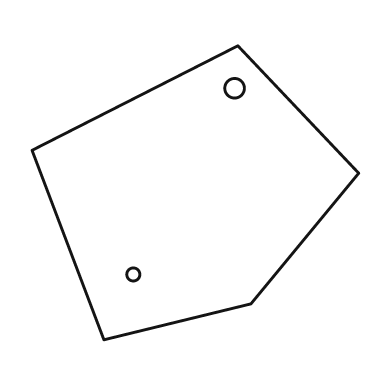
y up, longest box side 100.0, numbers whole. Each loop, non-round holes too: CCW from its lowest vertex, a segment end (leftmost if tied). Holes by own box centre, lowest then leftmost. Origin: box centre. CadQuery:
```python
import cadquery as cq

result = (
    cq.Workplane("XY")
    .moveTo(-28.0, -45.0)
    .lineTo(17.0, -34.0)
    .lineTo(50.0, 6.0)
    .lineTo(13.0, 45.0)
    .lineTo(-50.0, 13.0)
    .close()
    .moveTo(-19.0, -25.0)
    .circle(2.0)
    .moveTo(12.0, 32.0)
    .circle(3.0)
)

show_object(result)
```